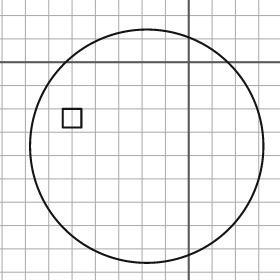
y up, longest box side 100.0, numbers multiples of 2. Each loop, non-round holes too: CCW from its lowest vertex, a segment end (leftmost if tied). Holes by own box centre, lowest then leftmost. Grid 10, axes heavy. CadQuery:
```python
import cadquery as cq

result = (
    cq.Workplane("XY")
    .moveTo(-18.0, -36.0)
    .circle(50.0)
    .moveTo(-54.0, -28.0)
    .lineTo(-46.0, -28.0)
    .lineTo(-46.0, -20.0)
    .lineTo(-54.0, -20.0)
    .close()
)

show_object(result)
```